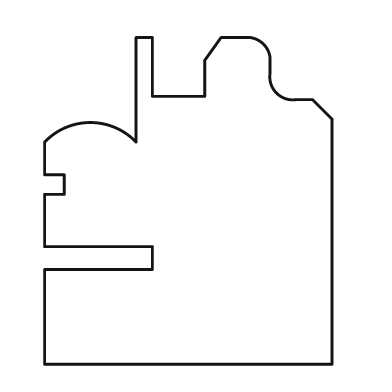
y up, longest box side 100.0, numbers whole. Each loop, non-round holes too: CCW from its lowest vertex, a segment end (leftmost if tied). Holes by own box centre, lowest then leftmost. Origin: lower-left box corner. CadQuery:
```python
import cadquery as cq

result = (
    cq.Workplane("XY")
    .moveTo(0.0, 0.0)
    .lineTo(88.0, 0.0)
    .lineTo(88.0, 75.0)
    .lineTo(82.0, 81.0)
    .lineTo(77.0, 81.0)
    .threePointArc((71.0, 83.0), (69.0, 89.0))
    .lineTo(69.0, 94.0)
    .threePointArc((67.0, 98.0), (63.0, 100.0))
    .lineTo(54.0, 100.0)
    .lineTo(49.0, 93.0)
    .lineTo(49.0, 82.0)
    .lineTo(33.0, 82.0)
    .lineTo(33.0, 100.0)
    .lineTo(28.0, 100.0)
    .lineTo(28.0, 68.0)
    .threePointArc((14.0, 74.0), (0.0, 68.0))
    .lineTo(0.0, 58.0)
    .lineTo(6.0, 58.0)
    .lineTo(6.0, 52.0)
    .lineTo(0.0, 52.0)
    .lineTo(0.0, 36.0)
    .lineTo(33.0, 36.0)
    .lineTo(33.0, 29.0)
    .lineTo(0.0, 29.0)
    .close()
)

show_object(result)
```